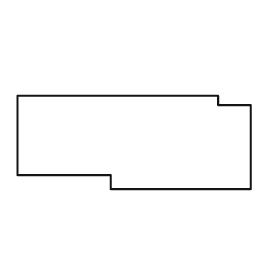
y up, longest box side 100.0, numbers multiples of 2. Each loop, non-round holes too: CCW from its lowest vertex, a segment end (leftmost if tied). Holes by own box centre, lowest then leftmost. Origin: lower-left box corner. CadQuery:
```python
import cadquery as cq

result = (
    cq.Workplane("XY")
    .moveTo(40.0, 0.0)
    .lineTo(100.0, 0.0)
    .lineTo(100.0, 36.0)
    .lineTo(86.0, 36.0)
    .lineTo(86.0, 40.0)
    .lineTo(0.0, 40.0)
    .lineTo(0.0, 6.0)
    .lineTo(40.0, 6.0)
    .close()
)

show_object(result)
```